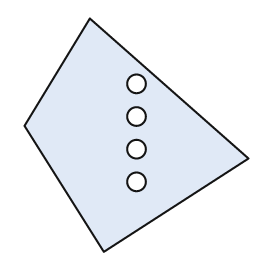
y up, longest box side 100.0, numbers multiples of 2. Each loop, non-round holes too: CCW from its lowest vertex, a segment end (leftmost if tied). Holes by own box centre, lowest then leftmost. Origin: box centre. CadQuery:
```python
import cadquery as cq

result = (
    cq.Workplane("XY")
    .moveTo(-14.0, -50.0)
    .lineTo(48.0, -10.0)
    .lineTo(-20.0, 50.0)
    .lineTo(-48.0, 4.0)
    .close()
    .moveTo(0.0, -20.0)
    .circle(4.0)
    .moveTo(0.0, -6.0)
    .circle(4.0)
    .moveTo(0.0, 8.0)
    .circle(4.0)
    .moveTo(0.0, 22.0)
    .circle(4.0)
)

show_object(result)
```